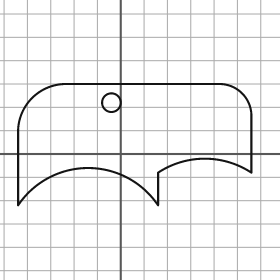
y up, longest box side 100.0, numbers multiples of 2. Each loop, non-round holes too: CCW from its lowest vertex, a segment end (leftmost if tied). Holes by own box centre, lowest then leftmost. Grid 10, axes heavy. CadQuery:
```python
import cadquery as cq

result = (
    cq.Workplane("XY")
    .moveTo(-44.0, -22.0)
    .threePointArc((-14.0, -6.0), (16.0, -22.0))
    .lineTo(16.0, -8.0)
    .threePointArc((36.0, -2.0), (56.0, -8.0))
    .lineTo(56.0, 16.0)
    .threePointArc((52.0, 26.0), (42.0, 30.0))
    .lineTo(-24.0, 30.0)
    .threePointArc((-38.0, 24.0), (-44.0, 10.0))
    .close()
    .moveTo(-4.0, 22.0)
    .circle(4.0)
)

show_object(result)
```